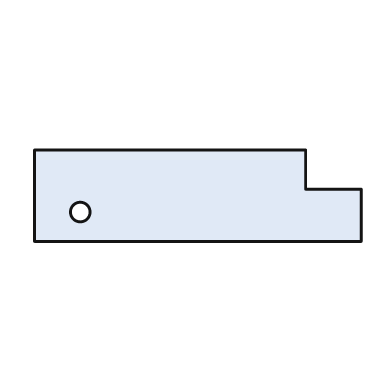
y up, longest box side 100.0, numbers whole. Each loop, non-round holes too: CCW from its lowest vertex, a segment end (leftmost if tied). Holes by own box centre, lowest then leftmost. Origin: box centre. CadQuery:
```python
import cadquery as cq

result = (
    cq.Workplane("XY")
    .moveTo(-50.0, -14.0)
    .lineTo(50.0, -14.0)
    .lineTo(50.0, 2.0)
    .lineTo(33.0, 2.0)
    .lineTo(33.0, 14.0)
    .lineTo(-50.0, 14.0)
    .close()
    .moveTo(-36.0, -5.0)
    .circle(3.0)
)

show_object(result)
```